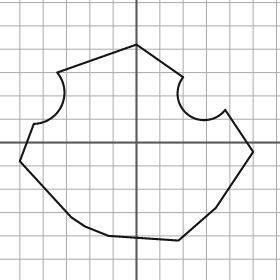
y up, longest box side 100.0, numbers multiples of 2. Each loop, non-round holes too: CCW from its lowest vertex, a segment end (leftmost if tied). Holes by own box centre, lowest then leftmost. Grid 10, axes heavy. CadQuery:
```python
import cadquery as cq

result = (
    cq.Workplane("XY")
    .moveTo(18.0, -42.0)
    .lineTo(34.0, -28.0)
    .lineTo(50.0, -4.0)
    .lineTo(38.0, 14.0)
    .threePointArc((22.0, 12.0), (20.0, 28.0))
    .lineTo(0.0, 42.0)
    .lineTo(-34.0, 30.0)
    .threePointArc((-32.0, 16.0), (-44.0, 8.0))
    .lineTo(-50.0, -8.0)
    .lineTo(-28.0, -32.0)
    .lineTo(-22.0, -36.0)
    .lineTo(-12.0, -40.0)
    .close()
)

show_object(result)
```